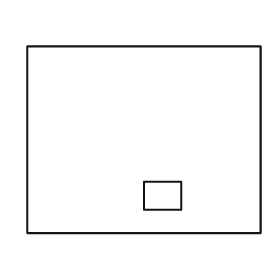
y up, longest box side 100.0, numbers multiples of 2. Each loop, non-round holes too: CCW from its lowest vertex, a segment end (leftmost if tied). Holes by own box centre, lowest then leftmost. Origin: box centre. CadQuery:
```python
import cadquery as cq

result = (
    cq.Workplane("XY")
    .moveTo(-50.0, -40.0)
    .lineTo(50.0, -40.0)
    .lineTo(50.0, 40.0)
    .lineTo(-50.0, 40.0)
    .close()
    .moveTo(0.0, -30.0)
    .lineTo(16.0, -30.0)
    .lineTo(16.0, -18.0)
    .lineTo(0.0, -18.0)
    .close()
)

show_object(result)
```